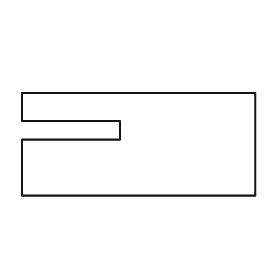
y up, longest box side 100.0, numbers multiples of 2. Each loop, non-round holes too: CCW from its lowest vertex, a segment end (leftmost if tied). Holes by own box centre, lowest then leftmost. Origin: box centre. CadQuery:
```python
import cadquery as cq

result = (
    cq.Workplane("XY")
    .moveTo(-50.0, -22.0)
    .lineTo(50.0, -22.0)
    .lineTo(50.0, 22.0)
    .lineTo(-50.0, 22.0)
    .lineTo(-50.0, 10.0)
    .lineTo(-8.0, 10.0)
    .lineTo(-8.0, 2.0)
    .lineTo(-50.0, 2.0)
    .close()
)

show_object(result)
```